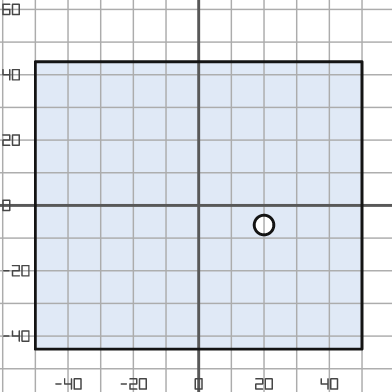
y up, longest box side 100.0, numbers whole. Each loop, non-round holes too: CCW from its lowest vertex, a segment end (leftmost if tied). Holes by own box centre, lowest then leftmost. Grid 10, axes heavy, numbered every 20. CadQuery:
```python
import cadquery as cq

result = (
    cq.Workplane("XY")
    .moveTo(-50.0, -44.0)
    .lineTo(50.0, -44.0)
    .lineTo(50.0, 44.0)
    .lineTo(-50.0, 44.0)
    .close()
    .moveTo(20.0, -6.0)
    .circle(3.0)
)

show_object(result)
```